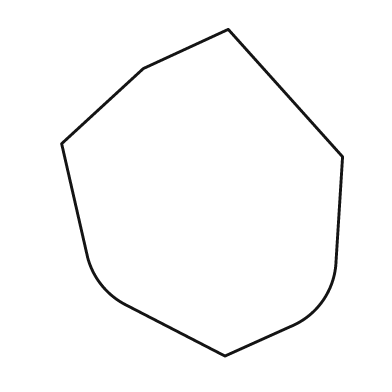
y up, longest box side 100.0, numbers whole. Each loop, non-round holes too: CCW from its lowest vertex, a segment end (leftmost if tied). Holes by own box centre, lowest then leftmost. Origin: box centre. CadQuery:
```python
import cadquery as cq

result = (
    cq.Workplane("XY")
    .moveTo(7.0, -50.0)
    .lineTo(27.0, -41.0)
    .threePointArc((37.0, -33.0), (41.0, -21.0))
    .lineTo(43.0, 11.0)
    .lineTo(8.0, 50.0)
    .lineTo(-18.0, 38.0)
    .lineTo(-43.0, 15.0)
    .lineTo(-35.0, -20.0)
    .threePointArc((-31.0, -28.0), (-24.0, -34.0))
    .close()
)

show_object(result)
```